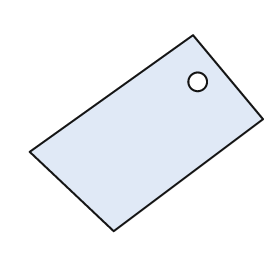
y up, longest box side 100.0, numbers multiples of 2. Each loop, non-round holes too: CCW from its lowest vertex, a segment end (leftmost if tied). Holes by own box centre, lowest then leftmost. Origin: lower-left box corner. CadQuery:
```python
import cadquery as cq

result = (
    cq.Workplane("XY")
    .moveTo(36.0, 0.0)
    .lineTo(100.0, 48.0)
    .lineTo(70.0, 84.0)
    .lineTo(0.0, 34.0)
    .close()
    .moveTo(72.0, 64.0)
    .circle(4.0)
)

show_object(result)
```